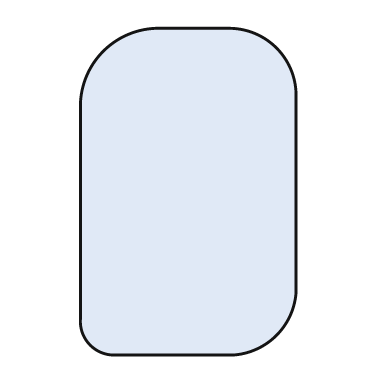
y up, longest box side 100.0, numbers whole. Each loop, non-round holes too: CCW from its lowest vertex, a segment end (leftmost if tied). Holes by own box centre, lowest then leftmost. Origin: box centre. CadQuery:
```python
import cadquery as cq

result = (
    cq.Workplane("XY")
    .moveTo(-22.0, -50.0)
    .lineTo(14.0, -50.0)
    .threePointArc((27.0, -44.0), (33.0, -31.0))
    .lineTo(33.0, 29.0)
    .threePointArc((27.0, 44.0), (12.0, 50.0))
    .lineTo(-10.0, 50.0)
    .threePointArc((-26.0, 43.0), (-33.0, 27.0))
    .lineTo(-33.0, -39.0)
    .threePointArc((-30.0, -47.0), (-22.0, -50.0))
    .close()
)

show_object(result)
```